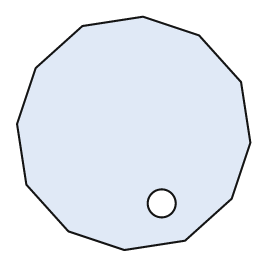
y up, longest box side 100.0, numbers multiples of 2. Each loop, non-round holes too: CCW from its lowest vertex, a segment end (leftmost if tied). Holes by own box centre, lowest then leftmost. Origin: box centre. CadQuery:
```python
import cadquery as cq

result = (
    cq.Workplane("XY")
    .moveTo(-4.0, -50.0)
    .lineTo(22.0, -46.0)
    .lineTo(42.0, -28.0)
    .lineTo(50.0, -4.0)
    .lineTo(46.0, 22.0)
    .lineTo(28.0, 42.0)
    .lineTo(4.0, 50.0)
    .lineTo(-22.0, 46.0)
    .lineTo(-42.0, 28.0)
    .lineTo(-50.0, 4.0)
    .lineTo(-46.0, -22.0)
    .lineTo(-28.0, -42.0)
    .close()
    .moveTo(12.0, -30.0)
    .circle(6.0)
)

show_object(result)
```